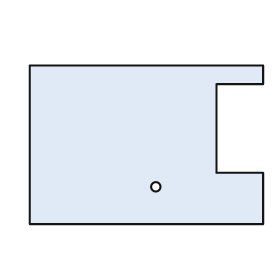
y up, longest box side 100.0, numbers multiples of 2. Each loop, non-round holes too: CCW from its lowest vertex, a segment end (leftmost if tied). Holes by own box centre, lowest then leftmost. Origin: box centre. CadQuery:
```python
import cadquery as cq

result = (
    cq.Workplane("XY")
    .moveTo(-50.0, -34.0)
    .lineTo(50.0, -34.0)
    .lineTo(50.0, -12.0)
    .lineTo(30.0, -12.0)
    .lineTo(30.0, 26.0)
    .lineTo(50.0, 26.0)
    .lineTo(50.0, 34.0)
    .lineTo(-50.0, 34.0)
    .close()
    .moveTo(4.0, -18.0)
    .circle(2.0)
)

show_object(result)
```